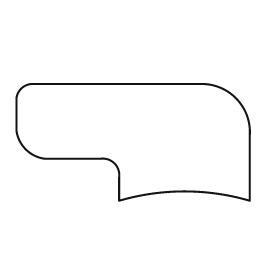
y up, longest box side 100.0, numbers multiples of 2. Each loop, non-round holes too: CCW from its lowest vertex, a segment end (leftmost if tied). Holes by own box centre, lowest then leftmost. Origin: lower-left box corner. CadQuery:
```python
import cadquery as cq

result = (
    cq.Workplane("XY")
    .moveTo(44.0, 0.0)
    .threePointArc((72.0, 4.0), (100.0, 0.0))
    .lineTo(100.0, 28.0)
    .threePointArc((94.0, 44.0), (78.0, 50.0))
    .lineTo(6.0, 50.0)
    .threePointArc((2.0, 48.0), (0.0, 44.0))
    .lineTo(0.0, 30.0)
    .threePointArc((4.0, 22.0), (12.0, 18.0))
    .lineTo(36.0, 18.0)
    .threePointArc((42.0, 16.0), (44.0, 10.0))
    .close()
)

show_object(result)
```